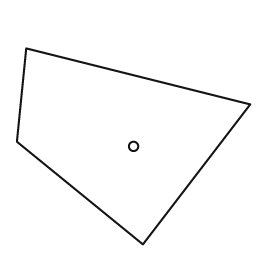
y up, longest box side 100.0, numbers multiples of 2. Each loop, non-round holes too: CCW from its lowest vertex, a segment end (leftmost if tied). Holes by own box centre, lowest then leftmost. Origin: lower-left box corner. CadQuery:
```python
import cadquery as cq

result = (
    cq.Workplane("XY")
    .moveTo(54.0, 0.0)
    .lineTo(100.0, 60.0)
    .lineTo(4.0, 84.0)
    .lineTo(0.0, 44.0)
    .close()
    .moveTo(50.0, 42.0)
    .circle(2.0)
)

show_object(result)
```